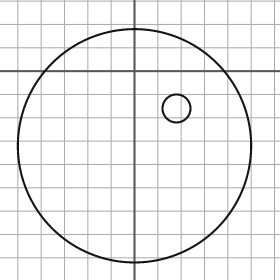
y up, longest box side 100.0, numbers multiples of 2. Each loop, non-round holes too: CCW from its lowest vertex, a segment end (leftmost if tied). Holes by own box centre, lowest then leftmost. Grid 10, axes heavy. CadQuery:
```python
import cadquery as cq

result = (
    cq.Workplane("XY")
    .moveTo(0.0, -32.0)
    .circle(50.0)
    .moveTo(18.0, -16.0)
    .circle(6.0)
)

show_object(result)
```